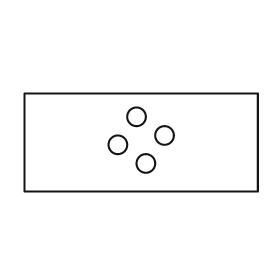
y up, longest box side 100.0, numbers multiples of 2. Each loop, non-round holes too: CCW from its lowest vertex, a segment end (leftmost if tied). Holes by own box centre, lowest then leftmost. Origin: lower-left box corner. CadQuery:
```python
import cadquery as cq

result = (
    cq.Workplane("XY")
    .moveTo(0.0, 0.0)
    .lineTo(100.0, 0.0)
    .lineTo(100.0, 42.0)
    .lineTo(0.0, 42.0)
    .close()
    .moveTo(52.0, 12.0)
    .circle(4.0)
    .moveTo(40.0, 20.0)
    .circle(4.0)
    .moveTo(60.0, 24.0)
    .circle(4.0)
    .moveTo(48.0, 32.0)
    .circle(4.0)
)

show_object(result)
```